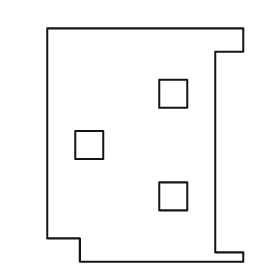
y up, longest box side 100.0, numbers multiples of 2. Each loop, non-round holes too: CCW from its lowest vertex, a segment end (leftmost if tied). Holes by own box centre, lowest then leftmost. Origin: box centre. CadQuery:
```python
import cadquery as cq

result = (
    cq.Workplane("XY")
    .moveTo(-28.0, -50.0)
    .lineTo(42.0, -50.0)
    .lineTo(42.0, -46.0)
    .lineTo(30.0, -46.0)
    .lineTo(30.0, 40.0)
    .lineTo(42.0, 40.0)
    .lineTo(42.0, 50.0)
    .lineTo(-42.0, 50.0)
    .lineTo(-42.0, -40.0)
    .lineTo(-28.0, -40.0)
    .close()
    .moveTo(6.0, -28.0)
    .lineTo(18.0, -28.0)
    .lineTo(18.0, -16.0)
    .lineTo(6.0, -16.0)
    .close()
    .moveTo(-30.0, -6.0)
    .lineTo(-18.0, -6.0)
    .lineTo(-18.0, 6.0)
    .lineTo(-30.0, 6.0)
    .close()
    .moveTo(6.0, 16.0)
    .lineTo(18.0, 16.0)
    .lineTo(18.0, 28.0)
    .lineTo(6.0, 28.0)
    .close()
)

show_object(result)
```